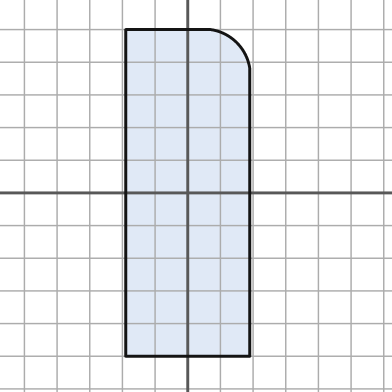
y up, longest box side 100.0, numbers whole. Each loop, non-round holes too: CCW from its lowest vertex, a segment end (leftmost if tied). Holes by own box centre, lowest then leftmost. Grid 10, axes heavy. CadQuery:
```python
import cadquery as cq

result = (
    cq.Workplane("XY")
    .moveTo(-19.0, -50.0)
    .lineTo(19.0, -50.0)
    .lineTo(19.0, 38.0)
    .threePointArc((15.0, 46.0), (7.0, 50.0))
    .lineTo(-19.0, 50.0)
    .close()
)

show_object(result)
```